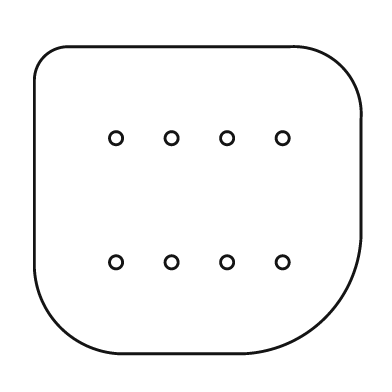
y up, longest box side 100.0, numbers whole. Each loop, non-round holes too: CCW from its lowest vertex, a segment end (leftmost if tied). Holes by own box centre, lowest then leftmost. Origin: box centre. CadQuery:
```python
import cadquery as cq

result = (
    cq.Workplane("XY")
    .moveTo(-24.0, -47.0)
    .lineTo(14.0, -47.0)
    .threePointArc((39.0, -36.0), (50.0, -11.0))
    .lineTo(50.0, 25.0)
    .threePointArc((44.0, 41.0), (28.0, 47.0))
    .lineTo(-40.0, 47.0)
    .threePointArc((-47.0, 44.0), (-50.0, 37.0))
    .lineTo(-50.0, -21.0)
    .threePointArc((-42.0, -39.0), (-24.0, -47.0))
    .close()
    .moveTo(-25.0, -19.0)
    .circle(2.0)
    .moveTo(-8.0, -19.0)
    .circle(2.0)
    .moveTo(9.0, -19.0)
    .circle(2.0)
    .moveTo(26.0, -19.0)
    .circle(2.0)
    .moveTo(-25.0, 19.0)
    .circle(2.0)
    .moveTo(-8.0, 19.0)
    .circle(2.0)
    .moveTo(9.0, 19.0)
    .circle(2.0)
    .moveTo(26.0, 19.0)
    .circle(2.0)
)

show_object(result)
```